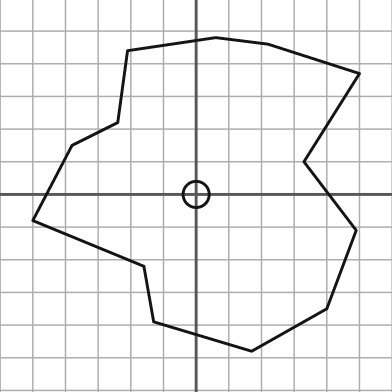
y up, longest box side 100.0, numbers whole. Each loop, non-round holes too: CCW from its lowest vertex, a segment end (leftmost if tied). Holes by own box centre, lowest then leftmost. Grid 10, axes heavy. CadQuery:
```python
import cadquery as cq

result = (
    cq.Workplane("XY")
    .moveTo(17.0, -48.0)
    .lineTo(40.0, -35.0)
    .lineTo(49.0, -11.0)
    .lineTo(33.0, 10.0)
    .lineTo(50.0, 37.0)
    .lineTo(22.0, 46.0)
    .lineTo(6.0, 48.0)
    .lineTo(-21.0, 44.0)
    .lineTo(-24.0, 22.0)
    .lineTo(-38.0, 15.0)
    .lineTo(-50.0, -8.0)
    .lineTo(-16.0, -22.0)
    .lineTo(-13.0, -39.0)
    .close()
    .moveTo(0.0, 0.0)
    .circle(4.0)
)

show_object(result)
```